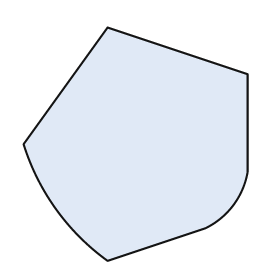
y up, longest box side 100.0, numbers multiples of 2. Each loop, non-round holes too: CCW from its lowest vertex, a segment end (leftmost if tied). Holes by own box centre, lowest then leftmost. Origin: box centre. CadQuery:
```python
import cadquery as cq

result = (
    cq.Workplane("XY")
    .moveTo(-12.0, -50.0)
    .lineTo(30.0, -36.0)
    .threePointArc((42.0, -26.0), (48.0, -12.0))
    .lineTo(48.0, 30.0)
    .lineTo(-12.0, 50.0)
    .lineTo(-48.0, 0.0)
    .threePointArc((-34.0, -28.0), (-12.0, -50.0))
    .close()
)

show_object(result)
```